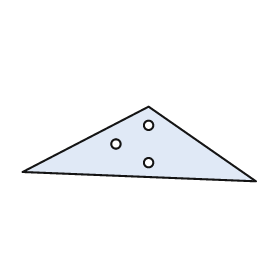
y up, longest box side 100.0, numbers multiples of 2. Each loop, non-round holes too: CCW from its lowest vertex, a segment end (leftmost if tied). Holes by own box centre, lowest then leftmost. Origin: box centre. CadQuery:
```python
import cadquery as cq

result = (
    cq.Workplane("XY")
    .moveTo(50.0, -16.0)
    .lineTo(4.0, 16.0)
    .lineTo(-50.0, -12.0)
    .close()
    .moveTo(4.0, -8.0)
    .circle(2.0)
    .moveTo(-10.0, 0.0)
    .circle(2.0)
    .moveTo(4.0, 8.0)
    .circle(2.0)
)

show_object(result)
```